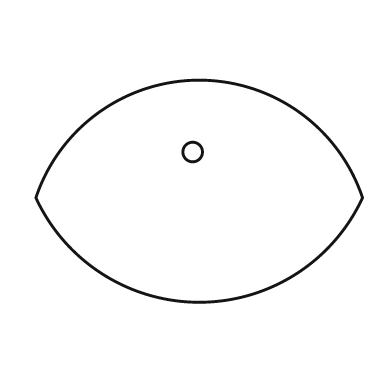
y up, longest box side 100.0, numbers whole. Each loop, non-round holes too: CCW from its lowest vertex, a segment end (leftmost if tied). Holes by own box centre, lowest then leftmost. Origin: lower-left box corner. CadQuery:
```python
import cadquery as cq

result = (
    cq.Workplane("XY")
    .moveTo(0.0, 32.0)
    .threePointArc((50.0, 0.0), (100.0, 32.0))
    .threePointArc((50.0, 68.0), (0.0, 32.0))
    .close()
    .moveTo(48.0, 46.0)
    .circle(3.0)
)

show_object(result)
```